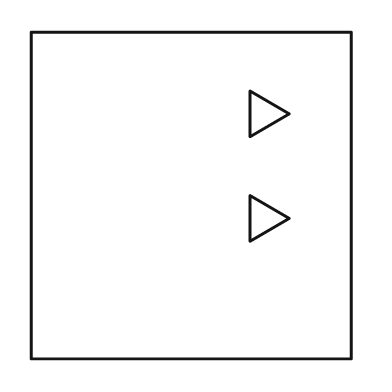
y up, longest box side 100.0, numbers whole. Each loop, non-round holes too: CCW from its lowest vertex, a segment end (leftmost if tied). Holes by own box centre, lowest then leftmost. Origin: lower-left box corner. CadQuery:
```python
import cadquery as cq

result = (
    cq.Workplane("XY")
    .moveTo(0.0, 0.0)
    .lineTo(98.0, 0.0)
    .lineTo(98.0, 100.0)
    .lineTo(0.0, 100.0)
    .close()
    .moveTo(67.0, 36.0)
    .lineTo(79.0, 43.0)
    .lineTo(67.0, 50.0)
    .close()
    .moveTo(67.0, 68.0)
    .lineTo(79.0, 75.0)
    .lineTo(67.0, 82.0)
    .close()
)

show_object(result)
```